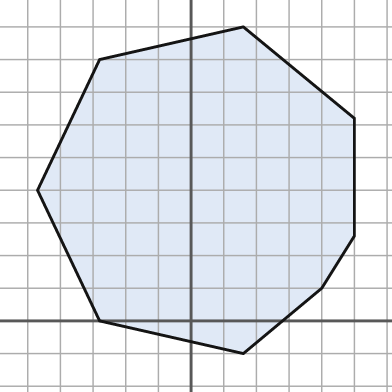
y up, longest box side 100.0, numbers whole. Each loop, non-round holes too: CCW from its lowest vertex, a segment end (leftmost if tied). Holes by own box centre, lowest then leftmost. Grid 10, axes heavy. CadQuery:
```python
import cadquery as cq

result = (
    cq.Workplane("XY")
    .moveTo(16.0, -10.0)
    .lineTo(40.0, 10.0)
    .lineTo(50.0, 26.0)
    .lineTo(50.0, 62.0)
    .lineTo(16.0, 90.0)
    .lineTo(-28.0, 80.0)
    .lineTo(-47.0, 40.0)
    .lineTo(-28.0, 0.0)
    .close()
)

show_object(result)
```